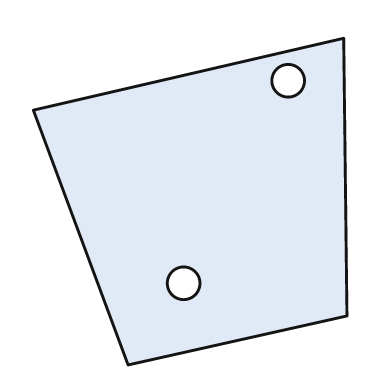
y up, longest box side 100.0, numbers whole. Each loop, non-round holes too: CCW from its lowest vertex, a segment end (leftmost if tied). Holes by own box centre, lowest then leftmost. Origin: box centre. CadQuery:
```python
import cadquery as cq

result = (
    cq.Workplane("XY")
    .moveTo(-19.0, -50.0)
    .lineTo(48.0, -35.0)
    .lineTo(47.0, 50.0)
    .lineTo(-48.0, 28.0)
    .close()
    .moveTo(-2.0, -25.0)
    .circle(5.0)
    .moveTo(30.0, 37.0)
    .circle(5.0)
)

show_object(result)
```